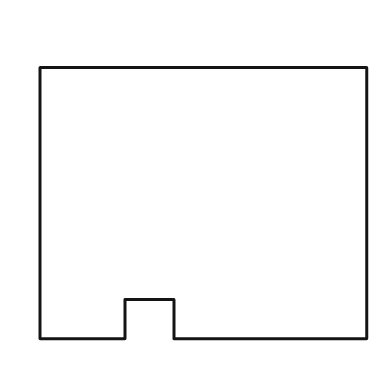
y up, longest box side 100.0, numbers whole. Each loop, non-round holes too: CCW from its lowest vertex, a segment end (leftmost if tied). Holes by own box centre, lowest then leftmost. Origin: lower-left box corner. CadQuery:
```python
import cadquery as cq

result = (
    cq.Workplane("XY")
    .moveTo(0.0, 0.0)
    .lineTo(26.0, 0.0)
    .lineTo(26.0, 12.0)
    .lineTo(41.0, 12.0)
    .lineTo(41.0, 0.0)
    .lineTo(100.0, 0.0)
    .lineTo(100.0, 83.0)
    .lineTo(0.0, 83.0)
    .close()
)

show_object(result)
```